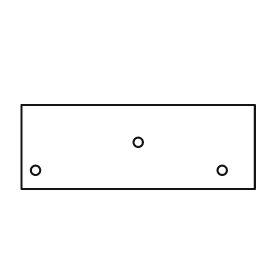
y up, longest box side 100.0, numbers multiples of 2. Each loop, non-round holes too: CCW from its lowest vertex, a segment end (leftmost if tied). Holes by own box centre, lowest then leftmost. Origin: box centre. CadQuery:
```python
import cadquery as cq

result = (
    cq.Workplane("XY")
    .moveTo(-50.0, -18.0)
    .lineTo(50.0, -18.0)
    .lineTo(50.0, 18.0)
    .lineTo(-50.0, 18.0)
    .close()
    .moveTo(-44.0, -10.0)
    .circle(2.0)
    .moveTo(36.0, -10.0)
    .circle(2.0)
    .moveTo(0.0, 2.0)
    .circle(2.0)
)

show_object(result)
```